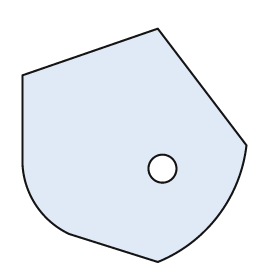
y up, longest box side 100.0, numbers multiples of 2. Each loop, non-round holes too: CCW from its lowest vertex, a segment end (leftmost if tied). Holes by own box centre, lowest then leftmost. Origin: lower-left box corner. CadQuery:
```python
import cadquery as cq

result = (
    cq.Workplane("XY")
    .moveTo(58.0, 0.0)
    .threePointArc((84.0, 20.0), (96.0, 50.0))
    .lineTo(58.0, 100.0)
    .lineTo(0.0, 80.0)
    .lineTo(0.0, 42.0)
    .threePointArc((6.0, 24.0), (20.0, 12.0))
    .close()
    .moveTo(60.0, 40.0)
    .circle(6.0)
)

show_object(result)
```